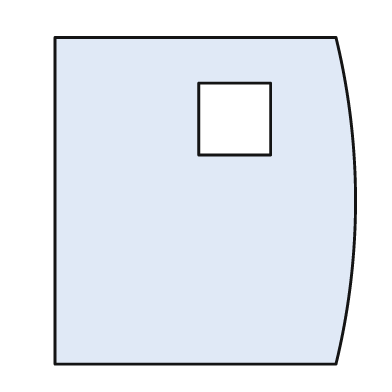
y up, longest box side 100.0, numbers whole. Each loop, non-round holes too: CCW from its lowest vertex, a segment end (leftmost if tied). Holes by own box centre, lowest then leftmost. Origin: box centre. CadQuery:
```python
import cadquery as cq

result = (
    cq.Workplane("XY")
    .moveTo(-46.0, -50.0)
    .lineTo(40.0, -50.0)
    .threePointArc((46.0, 0.0), (40.0, 50.0))
    .lineTo(-46.0, 50.0)
    .close()
    .moveTo(-2.0, 14.0)
    .lineTo(20.0, 14.0)
    .lineTo(20.0, 36.0)
    .lineTo(-2.0, 36.0)
    .close()
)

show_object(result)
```